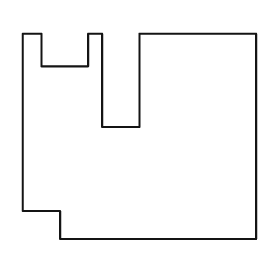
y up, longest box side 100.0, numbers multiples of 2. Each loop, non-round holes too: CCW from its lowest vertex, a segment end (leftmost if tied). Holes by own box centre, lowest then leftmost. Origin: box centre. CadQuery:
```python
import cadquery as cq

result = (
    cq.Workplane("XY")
    .moveTo(-34.0, -44.0)
    .lineTo(50.0, -44.0)
    .lineTo(50.0, 44.0)
    .lineTo(0.0, 44.0)
    .lineTo(0.0, 4.0)
    .lineTo(-16.0, 4.0)
    .lineTo(-16.0, 44.0)
    .lineTo(-22.0, 44.0)
    .lineTo(-22.0, 30.0)
    .lineTo(-42.0, 30.0)
    .lineTo(-42.0, 44.0)
    .lineTo(-50.0, 44.0)
    .lineTo(-50.0, -32.0)
    .lineTo(-34.0, -32.0)
    .close()
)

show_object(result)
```